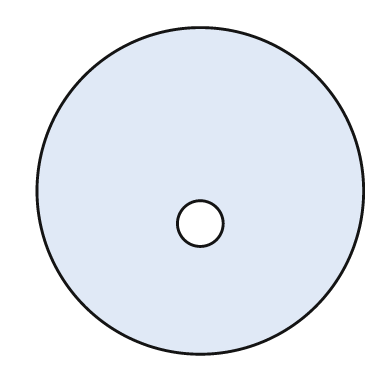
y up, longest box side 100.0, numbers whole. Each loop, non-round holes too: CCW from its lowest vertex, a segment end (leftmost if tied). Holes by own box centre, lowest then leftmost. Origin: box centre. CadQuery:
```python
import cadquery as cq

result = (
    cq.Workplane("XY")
    .moveTo(0.0, 0.0)
    .circle(50.0)
    .moveTo(0.0, -10.0)
    .circle(7.0)
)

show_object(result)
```